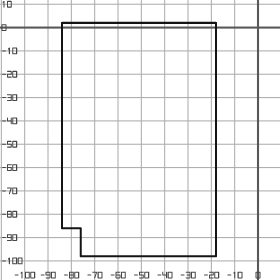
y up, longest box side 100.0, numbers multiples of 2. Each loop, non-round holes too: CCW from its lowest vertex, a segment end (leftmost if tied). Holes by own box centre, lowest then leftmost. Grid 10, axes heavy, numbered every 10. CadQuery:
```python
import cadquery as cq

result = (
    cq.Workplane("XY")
    .moveTo(-76.0, -98.0)
    .lineTo(-18.0, -98.0)
    .lineTo(-18.0, 2.0)
    .lineTo(-84.0, 2.0)
    .lineTo(-84.0, -86.0)
    .lineTo(-76.0, -86.0)
    .close()
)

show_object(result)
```